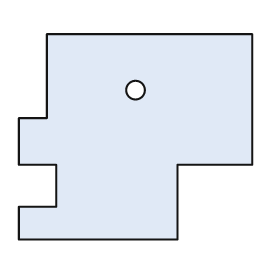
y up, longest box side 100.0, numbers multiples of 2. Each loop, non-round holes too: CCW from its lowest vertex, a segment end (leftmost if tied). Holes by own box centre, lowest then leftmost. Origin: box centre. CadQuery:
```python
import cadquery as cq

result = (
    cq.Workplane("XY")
    .moveTo(-50.0, -44.0)
    .lineTo(18.0, -44.0)
    .lineTo(18.0, -12.0)
    .lineTo(50.0, -12.0)
    .lineTo(50.0, 44.0)
    .lineTo(-38.0, 44.0)
    .lineTo(-38.0, 8.0)
    .lineTo(-50.0, 8.0)
    .lineTo(-50.0, -12.0)
    .lineTo(-34.0, -12.0)
    .lineTo(-34.0, -30.0)
    .lineTo(-50.0, -30.0)
    .close()
    .moveTo(0.0, 20.0)
    .circle(4.0)
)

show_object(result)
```